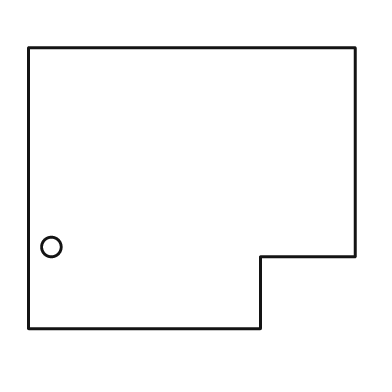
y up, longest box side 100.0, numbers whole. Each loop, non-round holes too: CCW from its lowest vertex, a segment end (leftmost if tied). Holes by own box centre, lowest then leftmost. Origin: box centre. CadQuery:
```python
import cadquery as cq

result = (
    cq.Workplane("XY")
    .moveTo(-50.0, -43.0)
    .lineTo(21.0, -43.0)
    .lineTo(21.0, -21.0)
    .lineTo(50.0, -21.0)
    .lineTo(50.0, 43.0)
    .lineTo(-50.0, 43.0)
    .close()
    .moveTo(-43.0, -18.0)
    .circle(3.0)
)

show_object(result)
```